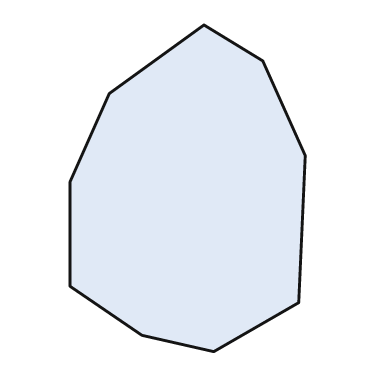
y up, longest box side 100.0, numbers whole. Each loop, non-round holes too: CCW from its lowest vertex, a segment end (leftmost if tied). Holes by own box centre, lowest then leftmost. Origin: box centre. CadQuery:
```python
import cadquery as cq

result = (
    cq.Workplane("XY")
    .moveTo(8.0, -50.0)
    .lineTo(34.0, -35.0)
    .lineTo(36.0, 10.0)
    .lineTo(23.0, 39.0)
    .lineTo(5.0, 50.0)
    .lineTo(-24.0, 29.0)
    .lineTo(-36.0, 2.0)
    .lineTo(-36.0, -30.0)
    .lineTo(-14.0, -45.0)
    .close()
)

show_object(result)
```